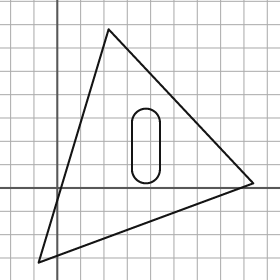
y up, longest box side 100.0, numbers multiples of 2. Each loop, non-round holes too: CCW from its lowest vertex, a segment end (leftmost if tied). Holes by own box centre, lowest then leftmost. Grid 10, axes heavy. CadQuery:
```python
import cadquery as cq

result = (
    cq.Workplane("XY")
    .moveTo(-8.0, -32.0)
    .lineTo(84.0, 2.0)
    .lineTo(22.0, 68.0)
    .close()
    .moveTo(32.0, 8.0)
    .threePointArc((38.0, 2.0), (44.0, 8.0))
    .lineTo(44.0, 28.0)
    .threePointArc((38.0, 34.0), (32.0, 28.0))
    .close()
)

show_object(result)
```